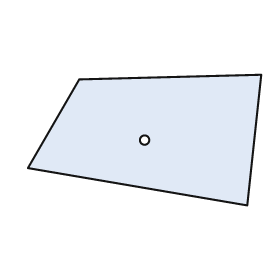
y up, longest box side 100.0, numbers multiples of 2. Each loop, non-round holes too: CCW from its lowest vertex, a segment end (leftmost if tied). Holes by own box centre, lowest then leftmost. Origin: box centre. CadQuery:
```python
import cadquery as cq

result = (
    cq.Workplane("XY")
    .moveTo(44.0, -28.0)
    .lineTo(50.0, 28.0)
    .lineTo(-28.0, 26.0)
    .lineTo(-50.0, -12.0)
    .close()
    .moveTo(0.0, 0.0)
    .circle(2.0)
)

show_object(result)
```